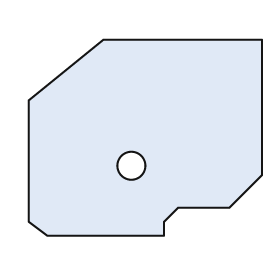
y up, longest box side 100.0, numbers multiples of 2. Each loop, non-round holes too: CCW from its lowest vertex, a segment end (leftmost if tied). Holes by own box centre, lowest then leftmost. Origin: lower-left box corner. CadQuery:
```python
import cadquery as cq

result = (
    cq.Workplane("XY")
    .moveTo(8.0, 0.0)
    .lineTo(58.0, 0.0)
    .lineTo(58.0, 6.0)
    .lineTo(64.0, 12.0)
    .lineTo(86.0, 12.0)
    .lineTo(100.0, 26.0)
    .lineTo(100.0, 84.0)
    .lineTo(32.0, 84.0)
    .lineTo(0.0, 58.0)
    .lineTo(0.0, 6.0)
    .close()
    .moveTo(44.0, 30.0)
    .circle(6.0)
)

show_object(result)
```